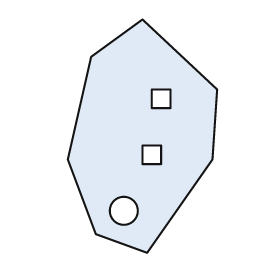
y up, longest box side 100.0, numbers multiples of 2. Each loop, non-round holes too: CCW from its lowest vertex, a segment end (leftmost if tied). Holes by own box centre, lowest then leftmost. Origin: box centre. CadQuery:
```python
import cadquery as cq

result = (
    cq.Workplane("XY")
    .moveTo(2.0, -50.0)
    .lineTo(30.0, -10.0)
    .lineTo(32.0, 20.0)
    .lineTo(0.0, 50.0)
    .lineTo(-22.0, 34.0)
    .lineTo(-32.0, -10.0)
    .lineTo(-20.0, -42.0)
    .close()
    .moveTo(-8.0, -32.0)
    .circle(6.0)
    .moveTo(0.0, -12.0)
    .lineTo(8.0, -12.0)
    .lineTo(8.0, -4.0)
    .lineTo(0.0, -4.0)
    .close()
    .moveTo(4.0, 12.0)
    .lineTo(12.0, 12.0)
    .lineTo(12.0, 20.0)
    .lineTo(4.0, 20.0)
    .close()
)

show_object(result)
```